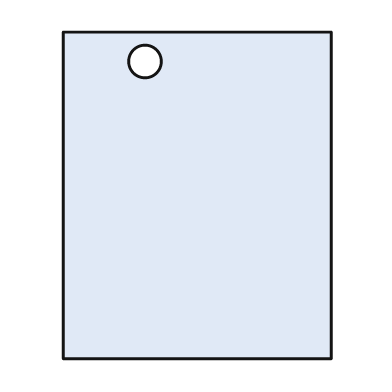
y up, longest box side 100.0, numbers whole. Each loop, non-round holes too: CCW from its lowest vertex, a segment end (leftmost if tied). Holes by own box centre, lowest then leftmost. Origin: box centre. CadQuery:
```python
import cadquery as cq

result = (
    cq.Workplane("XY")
    .moveTo(-41.0, -50.0)
    .lineTo(41.0, -50.0)
    .lineTo(41.0, 50.0)
    .lineTo(-41.0, 50.0)
    .close()
    .moveTo(-16.0, 41.0)
    .circle(5.0)
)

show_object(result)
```